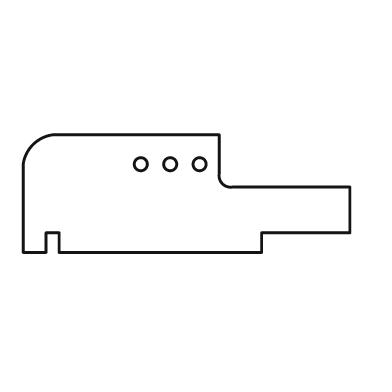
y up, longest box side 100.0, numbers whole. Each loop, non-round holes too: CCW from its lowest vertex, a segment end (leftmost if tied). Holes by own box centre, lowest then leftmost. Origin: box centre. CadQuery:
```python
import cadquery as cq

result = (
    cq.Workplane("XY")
    .moveTo(-50.0, -18.0)
    .lineTo(-43.0, -18.0)
    .lineTo(-43.0, -12.0)
    .lineTo(-39.0, -12.0)
    .lineTo(-39.0, -18.0)
    .lineTo(23.0, -18.0)
    .lineTo(23.0, -12.0)
    .lineTo(50.0, -12.0)
    .lineTo(50.0, 2.0)
    .lineTo(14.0, 2.0)
    .threePointArc((11.0, 3.0), (10.0, 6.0))
    .lineTo(10.0, 18.0)
    .lineTo(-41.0, 18.0)
    .threePointArc((-47.0, 15.0), (-50.0, 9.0))
    .close()
    .moveTo(-14.0, 9.0)
    .circle(2.0)
    .moveTo(-5.0, 9.0)
    .circle(2.0)
    .moveTo(4.0, 9.0)
    .circle(2.0)
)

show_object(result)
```